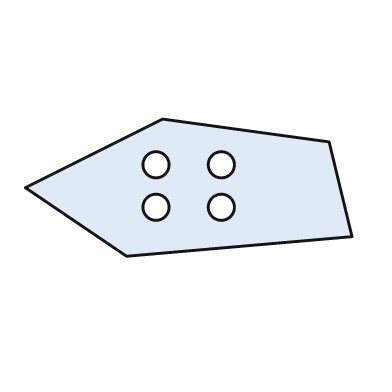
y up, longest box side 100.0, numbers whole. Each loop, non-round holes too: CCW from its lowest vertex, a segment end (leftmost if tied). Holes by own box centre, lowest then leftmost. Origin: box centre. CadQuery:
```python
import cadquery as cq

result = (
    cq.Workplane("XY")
    .moveTo(-19.0, -21.0)
    .lineTo(50.0, -15.0)
    .lineTo(43.0, 14.0)
    .lineTo(-8.0, 21.0)
    .lineTo(-50.0, 0.0)
    .close()
    .moveTo(-10.0, -6.0)
    .circle(4.0)
    .moveTo(10.0, -6.0)
    .circle(4.0)
    .moveTo(-10.0, 7.0)
    .circle(4.0)
    .moveTo(10.0, 7.0)
    .circle(4.0)
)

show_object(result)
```